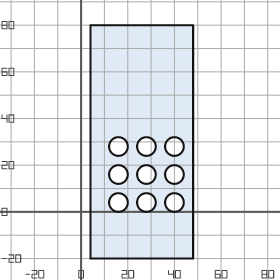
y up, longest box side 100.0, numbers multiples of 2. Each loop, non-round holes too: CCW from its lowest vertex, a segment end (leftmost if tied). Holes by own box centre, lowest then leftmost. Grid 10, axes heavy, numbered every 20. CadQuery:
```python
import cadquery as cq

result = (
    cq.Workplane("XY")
    .moveTo(4.0, -20.0)
    .lineTo(48.0, -20.0)
    .lineTo(48.0, 80.0)
    .lineTo(4.0, 80.0)
    .close()
    .moveTo(16.0, 4.0)
    .circle(4.0)
    .moveTo(28.0, 4.0)
    .circle(4.0)
    .moveTo(40.0, 4.0)
    .circle(4.0)
    .moveTo(16.0, 16.0)
    .circle(4.0)
    .moveTo(28.0, 16.0)
    .circle(4.0)
    .moveTo(40.0, 16.0)
    .circle(4.0)
    .moveTo(16.0, 28.0)
    .circle(4.0)
    .moveTo(28.0, 28.0)
    .circle(4.0)
    .moveTo(40.0, 28.0)
    .circle(4.0)
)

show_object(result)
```